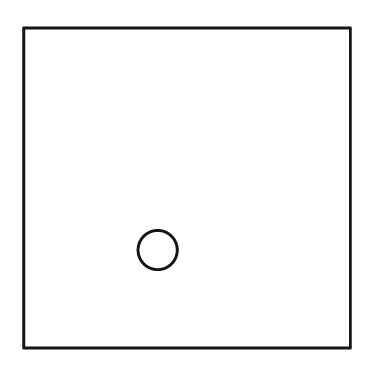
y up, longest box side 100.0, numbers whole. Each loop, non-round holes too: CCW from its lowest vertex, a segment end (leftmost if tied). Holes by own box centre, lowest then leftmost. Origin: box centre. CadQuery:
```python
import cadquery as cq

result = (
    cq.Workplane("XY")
    .moveTo(-50.0, -49.0)
    .lineTo(50.0, -49.0)
    .lineTo(50.0, 49.0)
    .lineTo(-50.0, 49.0)
    .close()
    .moveTo(-9.0, -19.0)
    .circle(6.0)
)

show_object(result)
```